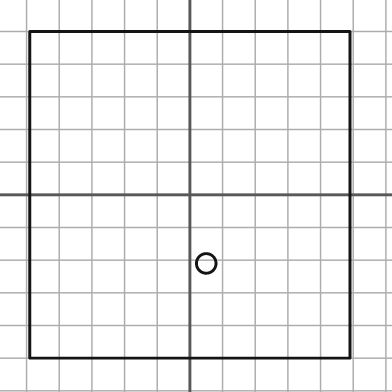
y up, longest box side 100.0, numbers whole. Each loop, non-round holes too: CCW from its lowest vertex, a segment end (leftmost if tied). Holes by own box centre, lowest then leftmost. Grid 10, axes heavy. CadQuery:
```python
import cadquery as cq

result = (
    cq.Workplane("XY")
    .moveTo(-49.0, -50.0)
    .lineTo(49.0, -50.0)
    .lineTo(49.0, 50.0)
    .lineTo(-49.0, 50.0)
    .close()
    .moveTo(5.0, -21.0)
    .circle(3.0)
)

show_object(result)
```